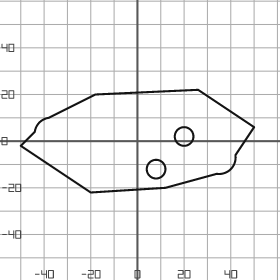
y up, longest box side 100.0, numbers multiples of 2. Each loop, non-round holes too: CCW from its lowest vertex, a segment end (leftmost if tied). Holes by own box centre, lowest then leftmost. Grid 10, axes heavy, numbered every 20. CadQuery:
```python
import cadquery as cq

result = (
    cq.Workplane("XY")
    .moveTo(-20.0, -22.0)
    .lineTo(12.0, -20.0)
    .lineTo(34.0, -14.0)
    .threePointArc((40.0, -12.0), (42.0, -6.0))
    .lineTo(50.0, 6.0)
    .lineTo(26.0, 22.0)
    .lineTo(-18.0, 20.0)
    .lineTo(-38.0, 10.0)
    .threePointArc((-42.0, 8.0), (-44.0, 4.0))
    .lineTo(-50.0, -2.0)
    .close()
    .moveTo(8.0, -12.0)
    .circle(4.0)
    .moveTo(20.0, 2.0)
    .circle(4.0)
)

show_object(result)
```